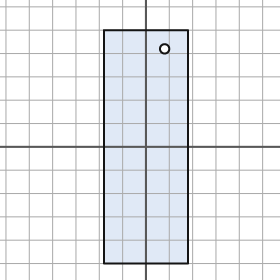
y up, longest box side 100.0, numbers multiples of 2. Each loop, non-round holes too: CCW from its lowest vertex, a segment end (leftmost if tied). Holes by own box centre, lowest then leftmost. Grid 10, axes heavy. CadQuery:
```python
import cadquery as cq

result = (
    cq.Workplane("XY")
    .moveTo(-18.0, -50.0)
    .lineTo(18.0, -50.0)
    .lineTo(18.0, 50.0)
    .lineTo(-18.0, 50.0)
    .close()
    .moveTo(8.0, 42.0)
    .circle(2.0)
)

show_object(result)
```